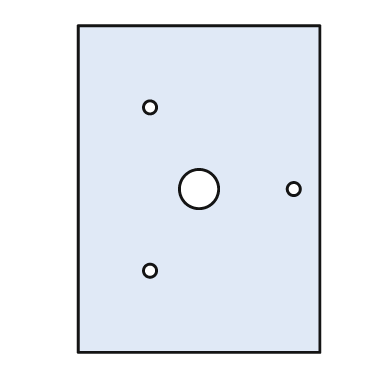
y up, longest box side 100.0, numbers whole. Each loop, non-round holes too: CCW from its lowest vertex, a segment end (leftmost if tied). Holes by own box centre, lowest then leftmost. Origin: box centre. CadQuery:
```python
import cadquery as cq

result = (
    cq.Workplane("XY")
    .moveTo(-37.0, -50.0)
    .lineTo(37.0, -50.0)
    .lineTo(37.0, 50.0)
    .lineTo(-37.0, 50.0)
    .close()
    .moveTo(-15.0, -25.0)
    .circle(2.0)
    .moveTo(0.0, 0.0)
    .circle(6.0)
    .moveTo(29.0, 0.0)
    .circle(2.0)
    .moveTo(-15.0, 25.0)
    .circle(2.0)
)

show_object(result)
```